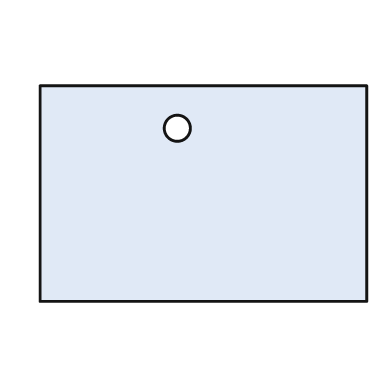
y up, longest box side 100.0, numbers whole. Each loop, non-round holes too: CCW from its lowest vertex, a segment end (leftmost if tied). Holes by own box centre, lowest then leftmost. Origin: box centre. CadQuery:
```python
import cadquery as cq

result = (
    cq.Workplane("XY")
    .moveTo(-50.0, -33.0)
    .lineTo(50.0, -33.0)
    .lineTo(50.0, 33.0)
    .lineTo(-50.0, 33.0)
    .close()
    .moveTo(-8.0, 20.0)
    .circle(4.0)
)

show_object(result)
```